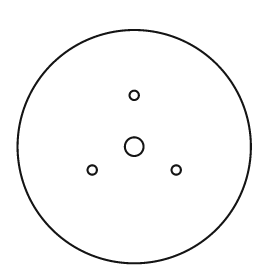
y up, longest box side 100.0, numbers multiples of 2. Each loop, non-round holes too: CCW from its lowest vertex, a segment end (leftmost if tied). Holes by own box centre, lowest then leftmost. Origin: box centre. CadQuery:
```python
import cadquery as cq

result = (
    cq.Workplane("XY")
    .moveTo(0.0, 0.0)
    .circle(50.0)
    .moveTo(-18.0, -10.0)
    .circle(2.0)
    .moveTo(18.0, -10.0)
    .circle(2.0)
    .moveTo(0.0, 0.0)
    .circle(4.0)
    .moveTo(0.0, 22.0)
    .circle(2.0)
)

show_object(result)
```